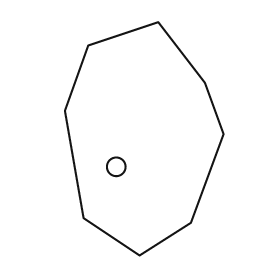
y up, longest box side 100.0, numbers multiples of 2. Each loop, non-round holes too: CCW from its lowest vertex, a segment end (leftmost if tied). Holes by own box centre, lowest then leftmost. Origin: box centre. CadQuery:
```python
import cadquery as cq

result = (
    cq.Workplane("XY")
    .moveTo(-2.0, -50.0)
    .lineTo(20.0, -36.0)
    .lineTo(34.0, 2.0)
    .lineTo(26.0, 24.0)
    .lineTo(6.0, 50.0)
    .lineTo(-24.0, 40.0)
    .lineTo(-34.0, 12.0)
    .lineTo(-26.0, -34.0)
    .close()
    .moveTo(-12.0, -12.0)
    .circle(4.0)
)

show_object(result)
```